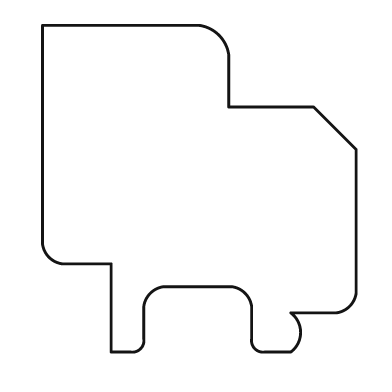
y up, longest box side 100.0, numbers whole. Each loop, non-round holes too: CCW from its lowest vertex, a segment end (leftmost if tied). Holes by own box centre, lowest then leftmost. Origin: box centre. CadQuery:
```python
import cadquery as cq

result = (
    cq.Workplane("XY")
    .moveTo(-27.0, -50.0)
    .lineTo(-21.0, -50.0)
    .threePointArc((-18.0, -49.0), (-17.0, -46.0))
    .lineTo(-17.0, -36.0)
    .threePointArc((-15.0, -32.0), (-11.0, -30.0))
    .lineTo(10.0, -30.0)
    .threePointArc((14.0, -32.0), (16.0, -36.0))
    .lineTo(16.0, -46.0)
    .threePointArc((17.0, -49.0), (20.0, -50.0))
    .lineTo(28.0, -50.0)
    .threePointArc((31.0, -44.0), (28.0, -38.0))
    .lineTo(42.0, -38.0)
    .threePointArc((46.0, -36.0), (48.0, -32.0))
    .lineTo(48.0, 12.0)
    .lineTo(35.0, 25.0)
    .lineTo(9.0, 25.0)
    .lineTo(9.0, 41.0)
    .threePointArc((6.0, 47.0), (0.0, 50.0))
    .lineTo(-48.0, 50.0)
    .lineTo(-48.0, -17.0)
    .threePointArc((-46.0, -21.0), (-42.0, -23.0))
    .lineTo(-27.0, -23.0)
    .close()
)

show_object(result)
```